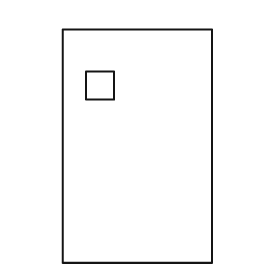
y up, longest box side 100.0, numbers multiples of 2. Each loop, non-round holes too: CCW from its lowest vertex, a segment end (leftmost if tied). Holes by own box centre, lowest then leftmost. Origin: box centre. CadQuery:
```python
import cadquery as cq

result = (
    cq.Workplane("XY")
    .moveTo(-32.0, -50.0)
    .lineTo(32.0, -50.0)
    .lineTo(32.0, 50.0)
    .lineTo(-32.0, 50.0)
    .close()
    .moveTo(-22.0, 20.0)
    .lineTo(-10.0, 20.0)
    .lineTo(-10.0, 32.0)
    .lineTo(-22.0, 32.0)
    .close()
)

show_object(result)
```